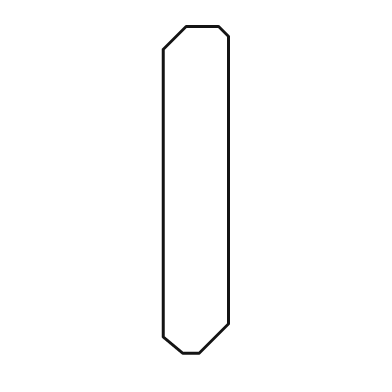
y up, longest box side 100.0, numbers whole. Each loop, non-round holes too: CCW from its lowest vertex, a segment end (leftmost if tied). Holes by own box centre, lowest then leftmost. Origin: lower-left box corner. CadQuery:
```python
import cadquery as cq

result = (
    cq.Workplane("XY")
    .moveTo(6.0, 0.0)
    .lineTo(11.0, 0.0)
    .lineTo(20.0, 9.0)
    .lineTo(20.0, 97.0)
    .lineTo(17.0, 100.0)
    .lineTo(7.0, 100.0)
    .lineTo(0.0, 93.0)
    .lineTo(0.0, 5.0)
    .close()
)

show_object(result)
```